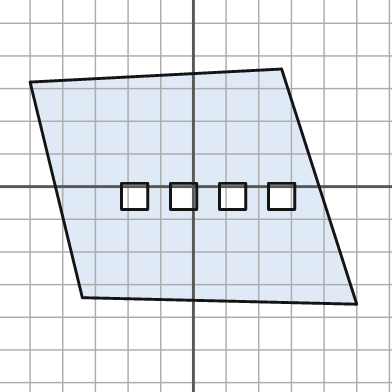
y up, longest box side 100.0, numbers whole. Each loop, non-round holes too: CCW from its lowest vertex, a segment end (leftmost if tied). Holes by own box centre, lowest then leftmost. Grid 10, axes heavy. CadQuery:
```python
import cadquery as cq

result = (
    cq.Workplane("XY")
    .moveTo(50.0, -36.0)
    .lineTo(27.0, 36.0)
    .lineTo(-50.0, 32.0)
    .lineTo(-34.0, -34.0)
    .close()
    .moveTo(-22.0, -7.0)
    .lineTo(-14.0, -7.0)
    .lineTo(-14.0, 1.0)
    .lineTo(-22.0, 1.0)
    .close()
    .moveTo(-7.0, -7.0)
    .lineTo(1.0, -7.0)
    .lineTo(1.0, 1.0)
    .lineTo(-7.0, 1.0)
    .close()
    .moveTo(8.0, -7.0)
    .lineTo(16.0, -7.0)
    .lineTo(16.0, 1.0)
    .lineTo(8.0, 1.0)
    .close()
    .moveTo(23.0, -7.0)
    .lineTo(31.0, -7.0)
    .lineTo(31.0, 1.0)
    .lineTo(23.0, 1.0)
    .close()
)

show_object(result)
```